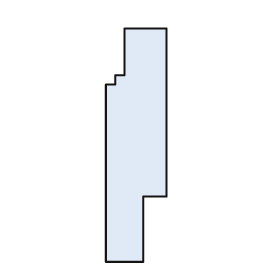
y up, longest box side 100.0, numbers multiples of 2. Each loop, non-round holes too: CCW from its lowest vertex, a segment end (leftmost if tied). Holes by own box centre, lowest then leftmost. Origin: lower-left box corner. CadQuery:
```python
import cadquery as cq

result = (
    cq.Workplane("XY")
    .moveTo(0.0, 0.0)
    .lineTo(16.0, 0.0)
    .lineTo(16.0, 28.0)
    .lineTo(26.0, 28.0)
    .lineTo(26.0, 100.0)
    .lineTo(8.0, 100.0)
    .lineTo(8.0, 80.0)
    .lineTo(4.0, 80.0)
    .lineTo(4.0, 76.0)
    .lineTo(0.0, 76.0)
    .close()
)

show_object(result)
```